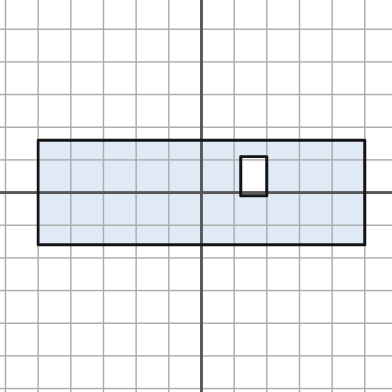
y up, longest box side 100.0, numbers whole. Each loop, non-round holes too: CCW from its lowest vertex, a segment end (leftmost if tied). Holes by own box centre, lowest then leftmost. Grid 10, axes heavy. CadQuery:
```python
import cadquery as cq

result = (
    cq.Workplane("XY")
    .moveTo(-50.0, -16.0)
    .lineTo(50.0, -16.0)
    .lineTo(50.0, 16.0)
    .lineTo(-50.0, 16.0)
    .close()
    .moveTo(12.0, -1.0)
    .lineTo(20.0, -1.0)
    .lineTo(20.0, 11.0)
    .lineTo(12.0, 11.0)
    .close()
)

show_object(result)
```